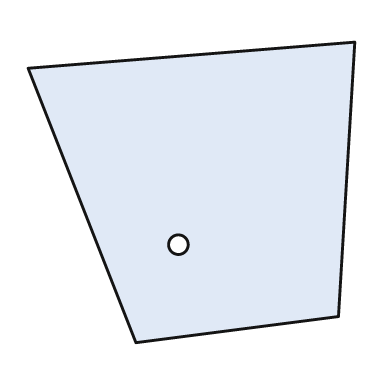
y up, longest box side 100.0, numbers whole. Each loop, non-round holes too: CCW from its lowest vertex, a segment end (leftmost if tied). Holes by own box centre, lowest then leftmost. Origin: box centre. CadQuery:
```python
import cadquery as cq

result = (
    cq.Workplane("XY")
    .moveTo(-17.0, -46.0)
    .lineTo(45.0, -38.0)
    .lineTo(50.0, 46.0)
    .lineTo(-50.0, 38.0)
    .close()
    .moveTo(-4.0, -16.0)
    .circle(3.0)
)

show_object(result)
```